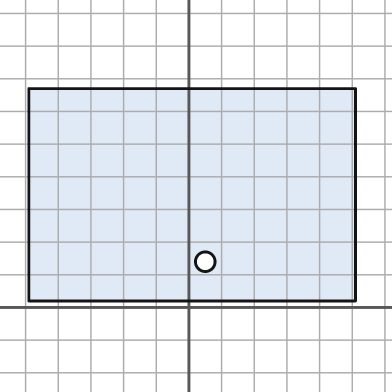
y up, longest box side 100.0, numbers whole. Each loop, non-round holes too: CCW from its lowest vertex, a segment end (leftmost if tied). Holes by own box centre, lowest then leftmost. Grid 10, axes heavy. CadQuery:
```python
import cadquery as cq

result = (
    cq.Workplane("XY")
    .moveTo(-49.0, 2.0)
    .lineTo(51.0, 2.0)
    .lineTo(51.0, 67.0)
    .lineTo(-49.0, 67.0)
    .close()
    .moveTo(5.0, 14.0)
    .circle(3.0)
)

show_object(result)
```